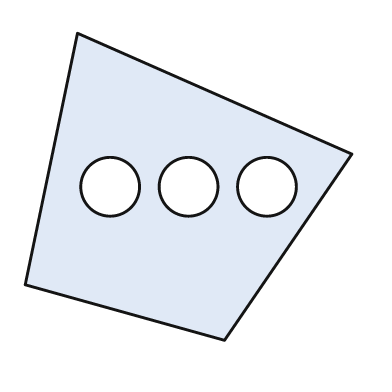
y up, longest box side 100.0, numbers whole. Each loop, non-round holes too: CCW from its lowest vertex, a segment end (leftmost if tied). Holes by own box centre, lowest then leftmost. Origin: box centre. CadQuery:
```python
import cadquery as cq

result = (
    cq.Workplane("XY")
    .moveTo(11.0, -47.0)
    .lineTo(50.0, 10.0)
    .lineTo(-34.0, 47.0)
    .lineTo(-50.0, -30.0)
    .close()
    .moveTo(-24.0, 0.0)
    .circle(9.0)
    .moveTo(0.0, 0.0)
    .circle(9.0)
    .moveTo(24.0, 0.0)
    .circle(9.0)
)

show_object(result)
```